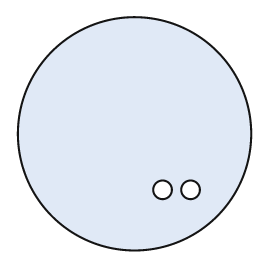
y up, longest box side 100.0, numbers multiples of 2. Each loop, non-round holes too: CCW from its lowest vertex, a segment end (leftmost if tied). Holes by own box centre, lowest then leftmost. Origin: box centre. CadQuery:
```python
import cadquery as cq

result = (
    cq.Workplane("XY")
    .moveTo(0.0, 0.0)
    .circle(50.0)
    .moveTo(12.0, -24.0)
    .circle(4.0)
    .moveTo(24.0, -24.0)
    .circle(4.0)
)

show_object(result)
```